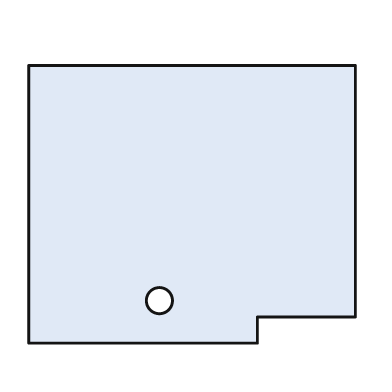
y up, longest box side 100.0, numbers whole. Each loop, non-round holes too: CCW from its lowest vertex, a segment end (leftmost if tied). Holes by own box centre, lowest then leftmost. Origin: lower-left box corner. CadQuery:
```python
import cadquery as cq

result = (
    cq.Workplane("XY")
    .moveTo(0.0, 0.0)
    .lineTo(70.0, 0.0)
    .lineTo(70.0, 8.0)
    .lineTo(100.0, 8.0)
    .lineTo(100.0, 85.0)
    .lineTo(0.0, 85.0)
    .close()
    .moveTo(40.0, 13.0)
    .circle(4.0)
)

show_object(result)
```